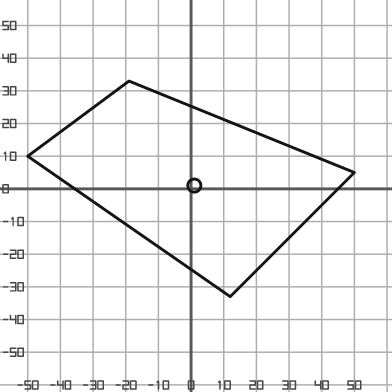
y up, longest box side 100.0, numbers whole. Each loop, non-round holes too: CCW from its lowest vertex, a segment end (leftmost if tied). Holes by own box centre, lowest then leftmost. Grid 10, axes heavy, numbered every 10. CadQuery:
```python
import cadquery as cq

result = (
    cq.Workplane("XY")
    .moveTo(12.0, -33.0)
    .lineTo(50.0, 5.0)
    .lineTo(-19.0, 33.0)
    .lineTo(-50.0, 10.0)
    .close()
    .moveTo(1.0, 1.0)
    .circle(2.0)
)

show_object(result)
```